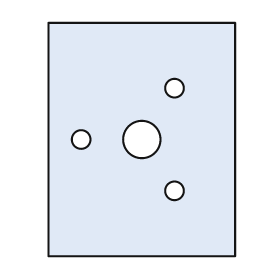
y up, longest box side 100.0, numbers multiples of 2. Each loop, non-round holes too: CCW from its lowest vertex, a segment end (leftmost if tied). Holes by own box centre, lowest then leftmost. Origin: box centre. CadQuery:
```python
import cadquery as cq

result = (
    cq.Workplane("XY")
    .moveTo(-40.0, -50.0)
    .lineTo(40.0, -50.0)
    .lineTo(40.0, 50.0)
    .lineTo(-40.0, 50.0)
    .close()
    .moveTo(14.0, -22.0)
    .circle(4.0)
    .moveTo(-26.0, 0.0)
    .circle(4.0)
    .moveTo(0.0, 0.0)
    .circle(8.0)
    .moveTo(14.0, 22.0)
    .circle(4.0)
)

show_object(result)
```